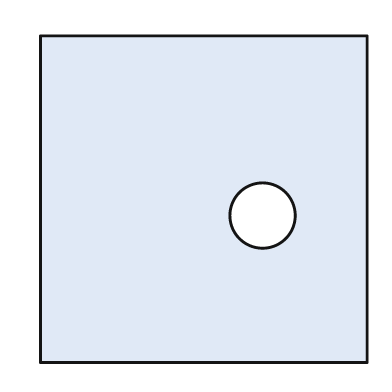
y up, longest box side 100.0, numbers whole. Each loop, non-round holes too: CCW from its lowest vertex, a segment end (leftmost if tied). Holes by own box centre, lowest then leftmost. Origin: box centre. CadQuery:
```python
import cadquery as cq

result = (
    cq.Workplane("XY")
    .moveTo(-50.0, -50.0)
    .lineTo(50.0, -50.0)
    .lineTo(50.0, 50.0)
    .lineTo(-50.0, 50.0)
    .close()
    .moveTo(18.0, -5.0)
    .circle(10.0)
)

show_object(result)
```